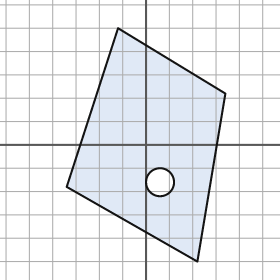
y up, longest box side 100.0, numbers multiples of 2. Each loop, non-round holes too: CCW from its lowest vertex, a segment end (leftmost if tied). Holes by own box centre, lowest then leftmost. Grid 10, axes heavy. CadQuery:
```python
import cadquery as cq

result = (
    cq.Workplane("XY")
    .moveTo(22.0, -50.0)
    .lineTo(34.0, 22.0)
    .lineTo(-12.0, 50.0)
    .lineTo(-34.0, -18.0)
    .close()
    .moveTo(6.0, -16.0)
    .circle(6.0)
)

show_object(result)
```